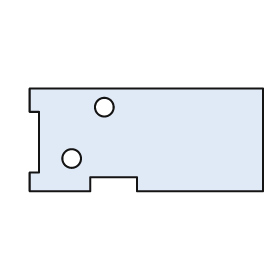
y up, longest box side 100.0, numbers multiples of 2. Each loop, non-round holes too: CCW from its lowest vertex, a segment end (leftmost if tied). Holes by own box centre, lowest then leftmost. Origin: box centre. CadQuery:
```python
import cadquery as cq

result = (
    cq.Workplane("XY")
    .moveTo(-50.0, -22.0)
    .lineTo(-24.0, -22.0)
    .lineTo(-24.0, -16.0)
    .lineTo(-4.0, -16.0)
    .lineTo(-4.0, -22.0)
    .lineTo(50.0, -22.0)
    .lineTo(50.0, 22.0)
    .lineTo(-50.0, 22.0)
    .lineTo(-50.0, 12.0)
    .lineTo(-46.0, 12.0)
    .lineTo(-46.0, -14.0)
    .lineTo(-50.0, -14.0)
    .close()
    .moveTo(-32.0, -8.0)
    .circle(4.0)
    .moveTo(-18.0, 14.0)
    .circle(4.0)
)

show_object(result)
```